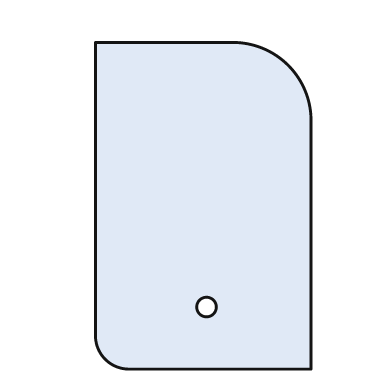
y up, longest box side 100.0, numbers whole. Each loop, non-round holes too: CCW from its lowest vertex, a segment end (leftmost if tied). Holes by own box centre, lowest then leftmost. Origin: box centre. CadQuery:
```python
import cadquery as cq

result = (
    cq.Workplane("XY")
    .moveTo(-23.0, -50.0)
    .lineTo(33.0, -50.0)
    .lineTo(33.0, 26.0)
    .threePointArc((26.0, 43.0), (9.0, 50.0))
    .lineTo(-33.0, 50.0)
    .lineTo(-33.0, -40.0)
    .threePointArc((-30.0, -47.0), (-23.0, -50.0))
    .close()
    .moveTo(1.0, -31.0)
    .circle(3.0)
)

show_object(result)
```